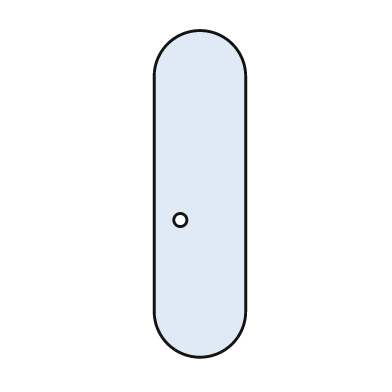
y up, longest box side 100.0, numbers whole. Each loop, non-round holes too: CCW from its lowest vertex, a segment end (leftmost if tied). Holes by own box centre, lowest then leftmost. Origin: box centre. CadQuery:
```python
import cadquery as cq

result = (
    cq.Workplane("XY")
    .moveTo(-14.0, -36.0)
    .threePointArc((0.0, -50.0), (14.0, -36.0))
    .lineTo(14.0, 36.0)
    .threePointArc((0.0, 50.0), (-14.0, 36.0))
    .close()
    .moveTo(-6.0, -8.0)
    .circle(2.0)
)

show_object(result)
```